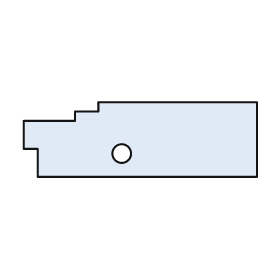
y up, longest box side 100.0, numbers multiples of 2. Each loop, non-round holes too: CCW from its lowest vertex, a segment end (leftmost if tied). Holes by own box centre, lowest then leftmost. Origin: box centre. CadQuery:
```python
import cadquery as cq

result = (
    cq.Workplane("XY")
    .moveTo(-44.0, -16.0)
    .lineTo(50.0, -16.0)
    .lineTo(50.0, 16.0)
    .lineTo(-18.0, 16.0)
    .lineTo(-18.0, 12.0)
    .lineTo(-28.0, 12.0)
    .lineTo(-28.0, 8.0)
    .lineTo(-50.0, 8.0)
    .lineTo(-50.0, -4.0)
    .lineTo(-44.0, -4.0)
    .close()
    .moveTo(-8.0, -6.0)
    .circle(4.0)
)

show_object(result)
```